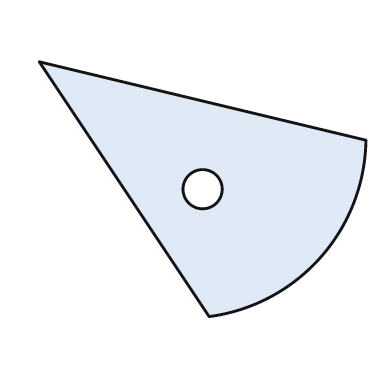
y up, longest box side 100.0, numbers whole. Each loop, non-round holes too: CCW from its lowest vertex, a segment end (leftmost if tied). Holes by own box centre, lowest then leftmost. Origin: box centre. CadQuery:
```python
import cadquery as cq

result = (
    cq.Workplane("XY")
    .moveTo(2.0, -39.0)
    .threePointArc((36.0, -21.0), (50.0, 15.0))
    .lineTo(-50.0, 39.0)
    .close()
    .moveTo(0.0, 0.0)
    .circle(6.0)
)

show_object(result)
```